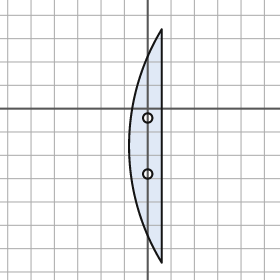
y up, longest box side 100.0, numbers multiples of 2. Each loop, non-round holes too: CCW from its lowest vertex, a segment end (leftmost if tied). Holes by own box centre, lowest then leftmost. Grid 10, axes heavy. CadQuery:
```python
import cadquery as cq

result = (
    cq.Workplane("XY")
    .moveTo(6.0, -66.0)
    .lineTo(6.0, 34.0)
    .threePointArc((-8.0, -16.0), (6.0, -66.0))
    .close()
    .moveTo(0.0, -28.0)
    .circle(2.0)
    .moveTo(0.0, -4.0)
    .circle(2.0)
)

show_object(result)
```